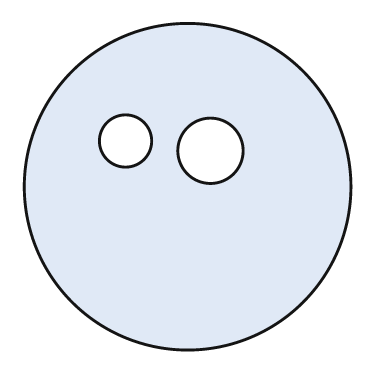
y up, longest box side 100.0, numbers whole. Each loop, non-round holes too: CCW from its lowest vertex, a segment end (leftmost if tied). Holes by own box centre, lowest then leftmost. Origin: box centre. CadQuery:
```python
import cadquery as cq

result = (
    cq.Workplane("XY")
    .moveTo(0.0, 0.0)
    .circle(50.0)
    .moveTo(7.0, 11.0)
    .circle(10.0)
    .moveTo(-19.0, 14.0)
    .circle(8.0)
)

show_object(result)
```